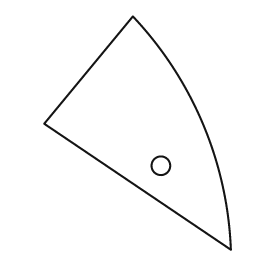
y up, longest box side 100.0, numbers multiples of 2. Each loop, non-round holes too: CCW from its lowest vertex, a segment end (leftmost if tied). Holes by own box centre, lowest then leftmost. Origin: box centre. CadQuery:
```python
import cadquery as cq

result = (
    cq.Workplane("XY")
    .moveTo(40.0, -50.0)
    .threePointArc((28.0, 4.0), (-2.0, 50.0))
    .lineTo(-40.0, 4.0)
    .close()
    .moveTo(10.0, -14.0)
    .circle(4.0)
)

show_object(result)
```